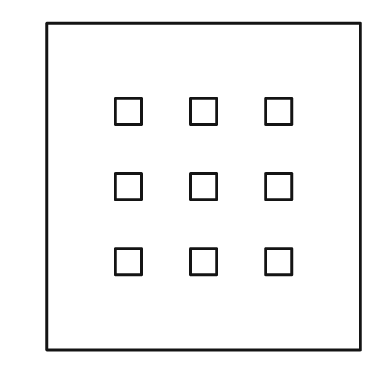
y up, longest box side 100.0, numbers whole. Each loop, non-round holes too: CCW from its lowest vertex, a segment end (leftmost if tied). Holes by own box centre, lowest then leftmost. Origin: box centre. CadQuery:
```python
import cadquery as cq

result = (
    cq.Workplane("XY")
    .moveTo(-48.0, -50.0)
    .lineTo(48.0, -50.0)
    .lineTo(48.0, 50.0)
    .lineTo(-48.0, 50.0)
    .close()
    .moveTo(-27.0, -27.0)
    .lineTo(-19.0, -27.0)
    .lineTo(-19.0, -19.0)
    .lineTo(-27.0, -19.0)
    .close()
    .moveTo(-4.0, -27.0)
    .lineTo(4.0, -27.0)
    .lineTo(4.0, -19.0)
    .lineTo(-4.0, -19.0)
    .close()
    .moveTo(19.0, -27.0)
    .lineTo(27.0, -27.0)
    .lineTo(27.0, -19.0)
    .lineTo(19.0, -19.0)
    .close()
    .moveTo(-27.0, -4.0)
    .lineTo(-19.0, -4.0)
    .lineTo(-19.0, 4.0)
    .lineTo(-27.0, 4.0)
    .close()
    .moveTo(-4.0, -4.0)
    .lineTo(4.0, -4.0)
    .lineTo(4.0, 4.0)
    .lineTo(-4.0, 4.0)
    .close()
    .moveTo(19.0, -4.0)
    .lineTo(27.0, -4.0)
    .lineTo(27.0, 4.0)
    .lineTo(19.0, 4.0)
    .close()
    .moveTo(-27.0, 19.0)
    .lineTo(-19.0, 19.0)
    .lineTo(-19.0, 27.0)
    .lineTo(-27.0, 27.0)
    .close()
    .moveTo(-4.0, 19.0)
    .lineTo(4.0, 19.0)
    .lineTo(4.0, 27.0)
    .lineTo(-4.0, 27.0)
    .close()
    .moveTo(19.0, 19.0)
    .lineTo(27.0, 19.0)
    .lineTo(27.0, 27.0)
    .lineTo(19.0, 27.0)
    .close()
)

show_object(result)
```